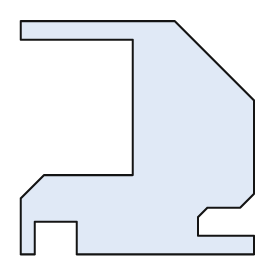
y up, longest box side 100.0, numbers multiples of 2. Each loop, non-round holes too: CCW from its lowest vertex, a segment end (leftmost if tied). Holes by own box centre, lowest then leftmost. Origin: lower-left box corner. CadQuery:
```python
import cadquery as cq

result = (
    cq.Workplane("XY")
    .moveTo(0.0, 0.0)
    .lineTo(6.0, 0.0)
    .lineTo(6.0, 14.0)
    .lineTo(24.0, 14.0)
    .lineTo(24.0, 0.0)
    .lineTo(100.0, 0.0)
    .lineTo(100.0, 8.0)
    .lineTo(76.0, 8.0)
    .lineTo(76.0, 16.0)
    .lineTo(80.0, 20.0)
    .lineTo(94.0, 20.0)
    .lineTo(100.0, 26.0)
    .lineTo(100.0, 66.0)
    .lineTo(66.0, 100.0)
    .lineTo(0.0, 100.0)
    .lineTo(0.0, 92.0)
    .lineTo(48.0, 92.0)
    .lineTo(48.0, 34.0)
    .lineTo(10.0, 34.0)
    .lineTo(0.0, 24.0)
    .close()
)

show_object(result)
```